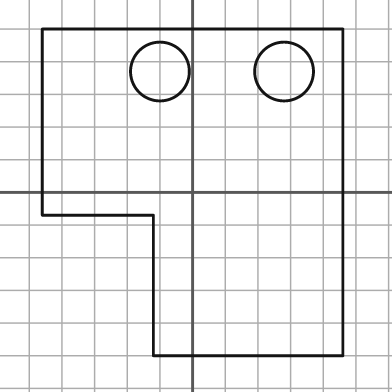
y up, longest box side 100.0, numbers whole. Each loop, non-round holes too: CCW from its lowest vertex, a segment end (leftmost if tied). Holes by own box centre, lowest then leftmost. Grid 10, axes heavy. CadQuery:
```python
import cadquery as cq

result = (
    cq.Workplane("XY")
    .moveTo(-12.0, -50.0)
    .lineTo(46.0, -50.0)
    .lineTo(46.0, 50.0)
    .lineTo(-46.0, 50.0)
    .lineTo(-46.0, -7.0)
    .lineTo(-12.0, -7.0)
    .close()
    .moveTo(-10.0, 37.0)
    .circle(9.0)
    .moveTo(28.0, 37.0)
    .circle(9.0)
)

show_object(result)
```